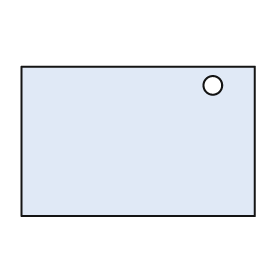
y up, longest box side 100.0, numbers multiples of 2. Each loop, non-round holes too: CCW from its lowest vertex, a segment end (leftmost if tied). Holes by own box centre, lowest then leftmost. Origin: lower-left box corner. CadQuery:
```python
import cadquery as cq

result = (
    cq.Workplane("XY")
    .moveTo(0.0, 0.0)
    .lineTo(100.0, 0.0)
    .lineTo(100.0, 64.0)
    .lineTo(0.0, 64.0)
    .close()
    .moveTo(82.0, 56.0)
    .circle(4.0)
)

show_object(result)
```